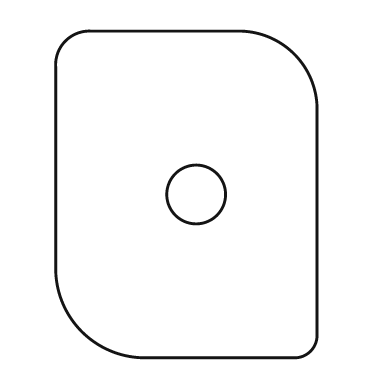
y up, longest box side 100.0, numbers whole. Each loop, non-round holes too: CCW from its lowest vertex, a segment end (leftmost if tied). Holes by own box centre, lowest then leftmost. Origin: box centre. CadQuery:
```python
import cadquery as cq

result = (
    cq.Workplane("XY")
    .moveTo(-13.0, -50.0)
    .lineTo(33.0, -50.0)
    .threePointArc((38.0, -48.0), (40.0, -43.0))
    .lineTo(40.0, 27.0)
    .threePointArc((33.0, 43.0), (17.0, 50.0))
    .lineTo(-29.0, 50.0)
    .threePointArc((-37.0, 47.0), (-40.0, 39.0))
    .lineTo(-40.0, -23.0)
    .threePointArc((-32.0, -42.0), (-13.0, -50.0))
    .close()
    .moveTo(3.0, 0.0)
    .circle(9.0)
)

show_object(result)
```